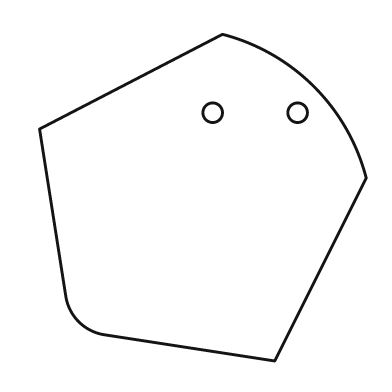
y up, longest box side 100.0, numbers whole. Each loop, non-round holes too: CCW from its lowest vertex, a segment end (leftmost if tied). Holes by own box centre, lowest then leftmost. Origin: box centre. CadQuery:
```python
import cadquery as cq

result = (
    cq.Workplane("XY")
    .moveTo(22.0, -50.0)
    .lineTo(50.0, 6.0)
    .threePointArc((34.0, 34.0), (6.0, 50.0))
    .lineTo(-50.0, 21.0)
    .lineTo(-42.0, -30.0)
    .threePointArc((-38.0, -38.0), (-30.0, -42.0))
    .close()
    .moveTo(3.0, 26.0)
    .circle(3.0)
    .moveTo(29.0, 26.0)
    .circle(3.0)
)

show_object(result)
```